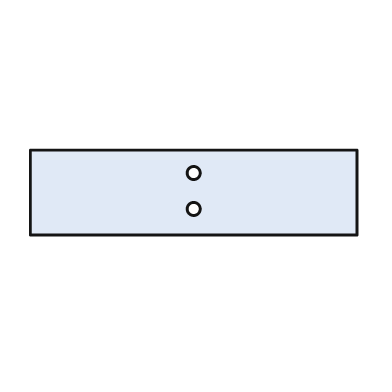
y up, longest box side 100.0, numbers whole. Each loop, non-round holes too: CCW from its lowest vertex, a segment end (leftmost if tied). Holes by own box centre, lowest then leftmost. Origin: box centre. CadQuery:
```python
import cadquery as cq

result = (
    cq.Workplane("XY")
    .moveTo(-50.0, -13.0)
    .lineTo(50.0, -13.0)
    .lineTo(50.0, 13.0)
    .lineTo(-50.0, 13.0)
    .close()
    .moveTo(0.0, -5.0)
    .circle(2.0)
    .moveTo(0.0, 6.0)
    .circle(2.0)
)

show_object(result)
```